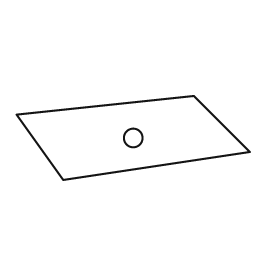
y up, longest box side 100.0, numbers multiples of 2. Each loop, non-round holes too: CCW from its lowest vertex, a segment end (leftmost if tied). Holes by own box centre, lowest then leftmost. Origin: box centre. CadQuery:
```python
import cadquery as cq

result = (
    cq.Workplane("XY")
    .moveTo(-30.0, -18.0)
    .lineTo(50.0, -6.0)
    .lineTo(26.0, 18.0)
    .lineTo(-50.0, 10.0)
    .close()
    .moveTo(0.0, 0.0)
    .circle(4.0)
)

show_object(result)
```